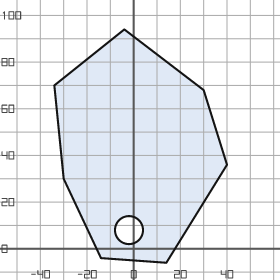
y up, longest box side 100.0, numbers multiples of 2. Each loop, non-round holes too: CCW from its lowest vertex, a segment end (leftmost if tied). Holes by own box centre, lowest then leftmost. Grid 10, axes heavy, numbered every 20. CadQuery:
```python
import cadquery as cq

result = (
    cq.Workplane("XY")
    .moveTo(14.0, -6.0)
    .lineTo(40.0, 36.0)
    .lineTo(30.0, 68.0)
    .lineTo(-4.0, 94.0)
    .lineTo(-34.0, 70.0)
    .lineTo(-30.0, 30.0)
    .lineTo(-14.0, -4.0)
    .close()
    .moveTo(-2.0, 8.0)
    .circle(6.0)
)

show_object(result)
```